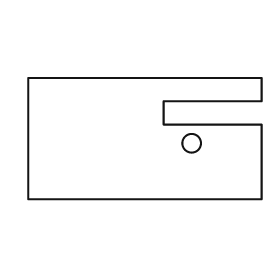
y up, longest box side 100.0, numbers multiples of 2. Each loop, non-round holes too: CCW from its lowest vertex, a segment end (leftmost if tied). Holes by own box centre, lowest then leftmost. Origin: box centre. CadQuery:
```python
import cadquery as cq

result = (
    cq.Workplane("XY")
    .moveTo(-50.0, -26.0)
    .lineTo(50.0, -26.0)
    .lineTo(50.0, 6.0)
    .lineTo(8.0, 6.0)
    .lineTo(8.0, 16.0)
    .lineTo(50.0, 16.0)
    .lineTo(50.0, 26.0)
    .lineTo(-50.0, 26.0)
    .close()
    .moveTo(20.0, -2.0)
    .circle(4.0)
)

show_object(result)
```